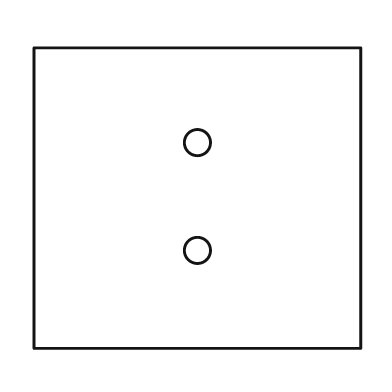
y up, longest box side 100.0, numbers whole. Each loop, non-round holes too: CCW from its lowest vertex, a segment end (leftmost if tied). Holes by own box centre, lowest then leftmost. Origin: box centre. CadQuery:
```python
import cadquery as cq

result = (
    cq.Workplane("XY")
    .moveTo(-50.0, -46.0)
    .lineTo(50.0, -46.0)
    .lineTo(50.0, 46.0)
    .lineTo(-50.0, 46.0)
    .close()
    .moveTo(0.0, -16.0)
    .circle(4.0)
    .moveTo(0.0, 17.0)
    .circle(4.0)
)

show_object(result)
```